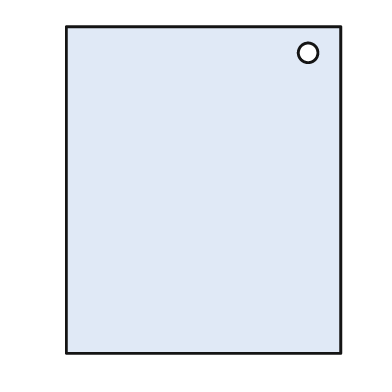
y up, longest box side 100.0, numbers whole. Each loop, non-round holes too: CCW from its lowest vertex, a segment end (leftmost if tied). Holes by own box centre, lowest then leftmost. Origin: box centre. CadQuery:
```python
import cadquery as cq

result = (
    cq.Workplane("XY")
    .moveTo(-42.0, -50.0)
    .lineTo(42.0, -50.0)
    .lineTo(42.0, 50.0)
    .lineTo(-42.0, 50.0)
    .close()
    .moveTo(32.0, 42.0)
    .circle(3.0)
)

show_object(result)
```